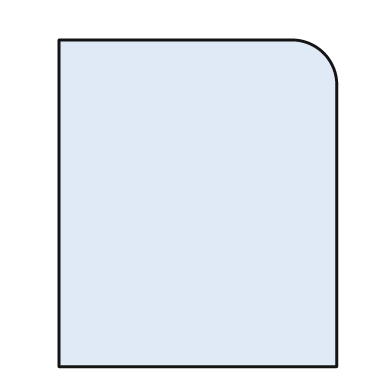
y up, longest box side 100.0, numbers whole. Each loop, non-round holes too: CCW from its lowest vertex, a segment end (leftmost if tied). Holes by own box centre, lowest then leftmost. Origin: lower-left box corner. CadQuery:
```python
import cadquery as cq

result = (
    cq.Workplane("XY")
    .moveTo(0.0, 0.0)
    .lineTo(85.0, 0.0)
    .lineTo(85.0, 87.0)
    .threePointArc((81.0, 96.0), (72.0, 100.0))
    .lineTo(0.0, 100.0)
    .close()
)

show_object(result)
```